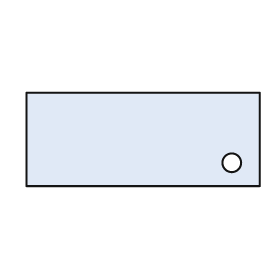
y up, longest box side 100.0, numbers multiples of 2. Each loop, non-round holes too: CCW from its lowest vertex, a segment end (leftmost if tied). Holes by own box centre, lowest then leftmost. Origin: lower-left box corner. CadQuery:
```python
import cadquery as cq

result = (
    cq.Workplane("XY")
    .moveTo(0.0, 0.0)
    .lineTo(100.0, 0.0)
    .lineTo(100.0, 40.0)
    .lineTo(0.0, 40.0)
    .close()
    .moveTo(88.0, 10.0)
    .circle(4.0)
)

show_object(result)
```